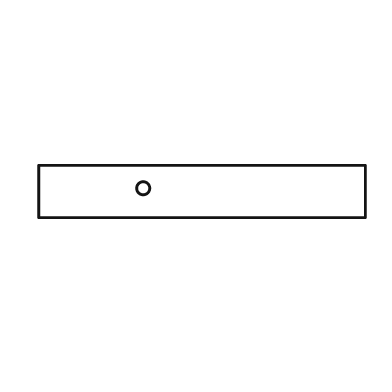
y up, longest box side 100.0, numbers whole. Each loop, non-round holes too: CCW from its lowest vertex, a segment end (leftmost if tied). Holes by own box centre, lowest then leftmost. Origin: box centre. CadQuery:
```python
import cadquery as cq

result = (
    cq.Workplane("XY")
    .moveTo(-50.0, -8.0)
    .lineTo(50.0, -8.0)
    .lineTo(50.0, 8.0)
    .lineTo(-50.0, 8.0)
    .close()
    .moveTo(-18.0, 1.0)
    .circle(2.0)
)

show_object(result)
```